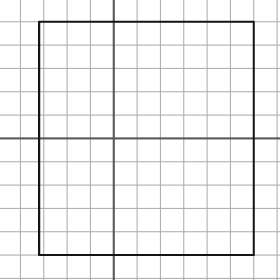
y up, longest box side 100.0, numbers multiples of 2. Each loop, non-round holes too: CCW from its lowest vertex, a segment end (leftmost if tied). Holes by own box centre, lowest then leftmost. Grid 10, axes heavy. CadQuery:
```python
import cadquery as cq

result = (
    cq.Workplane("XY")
    .moveTo(-32.0, -50.0)
    .lineTo(60.0, -50.0)
    .lineTo(60.0, 50.0)
    .lineTo(-32.0, 50.0)
    .close()
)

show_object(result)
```